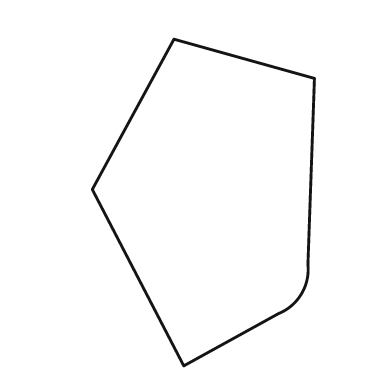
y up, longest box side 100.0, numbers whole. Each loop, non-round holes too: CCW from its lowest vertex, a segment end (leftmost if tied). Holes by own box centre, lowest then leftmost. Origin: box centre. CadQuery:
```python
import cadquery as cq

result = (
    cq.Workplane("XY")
    .moveTo(-6.0, -50.0)
    .lineTo(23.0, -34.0)
    .threePointArc((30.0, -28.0), (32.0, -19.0))
    .lineTo(34.0, 38.0)
    .lineTo(-9.0, 50.0)
    .lineTo(-34.0, 4.0)
    .close()
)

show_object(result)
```